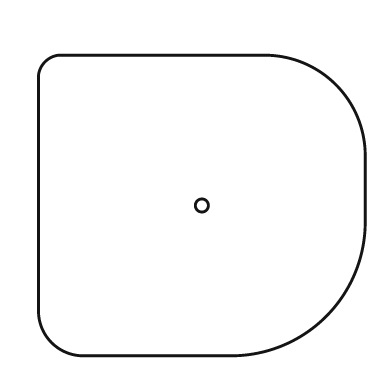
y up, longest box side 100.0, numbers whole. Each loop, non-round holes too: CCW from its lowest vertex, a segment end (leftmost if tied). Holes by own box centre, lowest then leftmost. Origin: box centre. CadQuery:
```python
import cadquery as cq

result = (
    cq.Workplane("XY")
    .moveTo(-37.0, -46.0)
    .lineTo(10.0, -46.0)
    .threePointArc((38.0, -34.0), (50.0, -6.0))
    .lineTo(50.0, 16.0)
    .threePointArc((41.0, 37.0), (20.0, 46.0))
    .lineTo(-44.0, 46.0)
    .threePointArc((-48.0, 44.0), (-50.0, 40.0))
    .lineTo(-50.0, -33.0)
    .threePointArc((-46.0, -42.0), (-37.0, -46.0))
    .close()
    .moveTo(0.0, 0.0)
    .circle(2.0)
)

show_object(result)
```